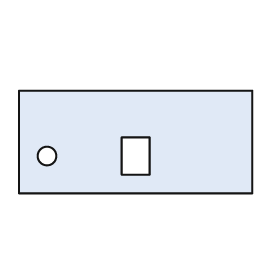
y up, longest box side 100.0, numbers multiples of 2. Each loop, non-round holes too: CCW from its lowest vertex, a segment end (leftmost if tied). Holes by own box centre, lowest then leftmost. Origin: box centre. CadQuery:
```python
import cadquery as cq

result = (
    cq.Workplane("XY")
    .moveTo(-50.0, -22.0)
    .lineTo(50.0, -22.0)
    .lineTo(50.0, 22.0)
    .lineTo(-50.0, 22.0)
    .close()
    .moveTo(-38.0, -6.0)
    .circle(4.0)
    .moveTo(-6.0, -14.0)
    .lineTo(6.0, -14.0)
    .lineTo(6.0, 2.0)
    .lineTo(-6.0, 2.0)
    .close()
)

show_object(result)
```